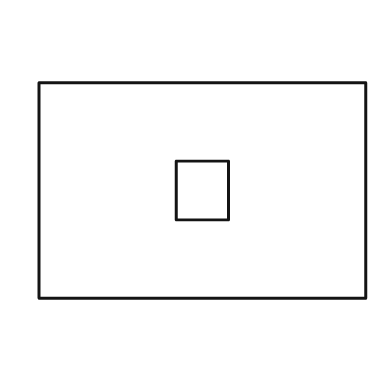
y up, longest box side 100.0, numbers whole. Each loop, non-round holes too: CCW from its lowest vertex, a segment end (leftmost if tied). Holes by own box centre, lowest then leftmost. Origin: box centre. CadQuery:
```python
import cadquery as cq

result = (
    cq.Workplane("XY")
    .moveTo(-50.0, -33.0)
    .lineTo(50.0, -33.0)
    .lineTo(50.0, 33.0)
    .lineTo(-50.0, 33.0)
    .close()
    .moveTo(-8.0, -9.0)
    .lineTo(8.0, -9.0)
    .lineTo(8.0, 9.0)
    .lineTo(-8.0, 9.0)
    .close()
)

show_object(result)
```